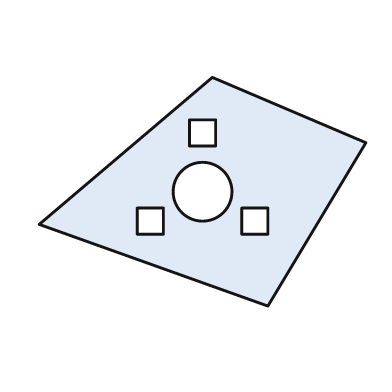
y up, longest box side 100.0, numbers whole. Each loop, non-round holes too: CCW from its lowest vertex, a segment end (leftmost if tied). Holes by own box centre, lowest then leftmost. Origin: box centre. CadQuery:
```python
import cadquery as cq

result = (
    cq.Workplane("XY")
    .moveTo(20.0, -35.0)
    .lineTo(50.0, 15.0)
    .lineTo(3.0, 35.0)
    .lineTo(-50.0, -10.0)
    .close()
    .moveTo(-20.0, -13.0)
    .lineTo(-12.0, -13.0)
    .lineTo(-12.0, -5.0)
    .lineTo(-20.0, -5.0)
    .close()
    .moveTo(12.0, -13.0)
    .lineTo(20.0, -13.0)
    .lineTo(20.0, -5.0)
    .lineTo(12.0, -5.0)
    .close()
    .moveTo(0.0, 0.0)
    .circle(9.0)
    .moveTo(-4.0, 14.0)
    .lineTo(4.0, 14.0)
    .lineTo(4.0, 22.0)
    .lineTo(-4.0, 22.0)
    .close()
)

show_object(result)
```